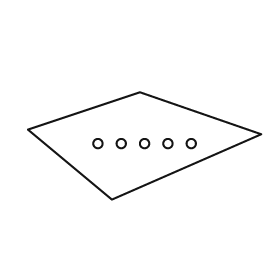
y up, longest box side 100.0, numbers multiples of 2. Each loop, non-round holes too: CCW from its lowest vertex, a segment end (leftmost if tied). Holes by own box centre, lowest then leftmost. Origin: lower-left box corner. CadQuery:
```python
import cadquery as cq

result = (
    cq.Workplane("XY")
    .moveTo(36.0, 0.0)
    .lineTo(100.0, 28.0)
    .lineTo(48.0, 46.0)
    .lineTo(0.0, 30.0)
    .close()
    .moveTo(30.0, 24.0)
    .circle(2.0)
    .moveTo(40.0, 24.0)
    .circle(2.0)
    .moveTo(50.0, 24.0)
    .circle(2.0)
    .moveTo(60.0, 24.0)
    .circle(2.0)
    .moveTo(70.0, 24.0)
    .circle(2.0)
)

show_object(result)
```